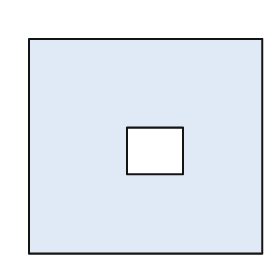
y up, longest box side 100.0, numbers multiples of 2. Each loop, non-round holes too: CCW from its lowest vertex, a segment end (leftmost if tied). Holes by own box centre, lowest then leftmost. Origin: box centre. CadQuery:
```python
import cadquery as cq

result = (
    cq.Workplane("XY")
    .moveTo(-50.0, -46.0)
    .lineTo(50.0, -46.0)
    .lineTo(50.0, 46.0)
    .lineTo(-50.0, 46.0)
    .close()
    .moveTo(-8.0, -12.0)
    .lineTo(16.0, -12.0)
    .lineTo(16.0, 8.0)
    .lineTo(-8.0, 8.0)
    .close()
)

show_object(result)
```